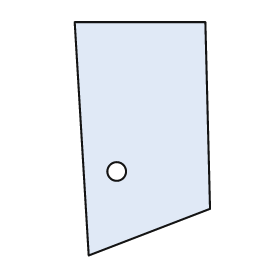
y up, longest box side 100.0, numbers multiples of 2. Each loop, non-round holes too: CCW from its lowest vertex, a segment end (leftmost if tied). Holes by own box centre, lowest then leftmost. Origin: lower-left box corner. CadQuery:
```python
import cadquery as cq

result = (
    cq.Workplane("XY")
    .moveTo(6.0, 0.0)
    .lineTo(58.0, 20.0)
    .lineTo(56.0, 100.0)
    .lineTo(0.0, 100.0)
    .close()
    .moveTo(18.0, 36.0)
    .circle(4.0)
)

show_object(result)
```